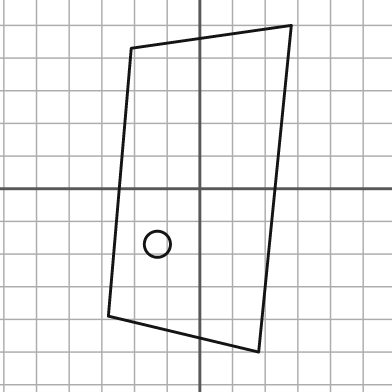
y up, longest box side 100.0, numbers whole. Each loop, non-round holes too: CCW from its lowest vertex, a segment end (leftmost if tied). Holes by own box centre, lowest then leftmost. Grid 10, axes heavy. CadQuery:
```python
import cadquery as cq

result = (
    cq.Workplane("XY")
    .moveTo(18.0, -50.0)
    .lineTo(28.0, 50.0)
    .lineTo(-21.0, 43.0)
    .lineTo(-28.0, -39.0)
    .close()
    .moveTo(-13.0, -17.0)
    .circle(4.0)
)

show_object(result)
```